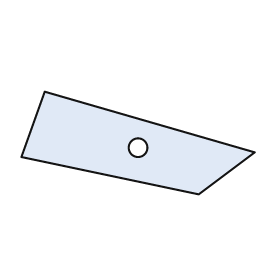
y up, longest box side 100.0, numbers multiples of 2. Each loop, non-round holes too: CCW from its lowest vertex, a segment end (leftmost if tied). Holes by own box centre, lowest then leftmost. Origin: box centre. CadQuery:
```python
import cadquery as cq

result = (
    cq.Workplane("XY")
    .moveTo(26.0, -22.0)
    .lineTo(50.0, -4.0)
    .lineTo(-40.0, 22.0)
    .lineTo(-50.0, -6.0)
    .close()
    .moveTo(0.0, -2.0)
    .circle(4.0)
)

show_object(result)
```